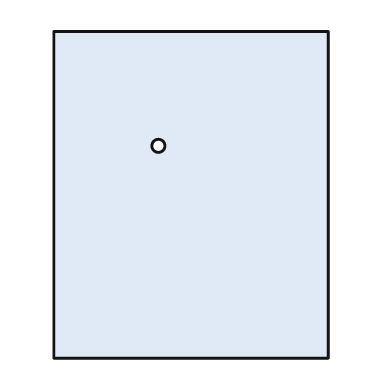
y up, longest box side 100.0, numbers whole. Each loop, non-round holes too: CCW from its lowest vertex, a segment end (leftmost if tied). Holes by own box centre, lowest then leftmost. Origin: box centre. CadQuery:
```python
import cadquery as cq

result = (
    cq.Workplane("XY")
    .moveTo(-42.0, -50.0)
    .lineTo(42.0, -50.0)
    .lineTo(42.0, 50.0)
    .lineTo(-42.0, 50.0)
    .close()
    .moveTo(-10.0, 15.0)
    .circle(2.0)
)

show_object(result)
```